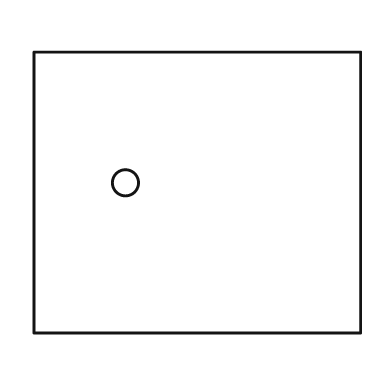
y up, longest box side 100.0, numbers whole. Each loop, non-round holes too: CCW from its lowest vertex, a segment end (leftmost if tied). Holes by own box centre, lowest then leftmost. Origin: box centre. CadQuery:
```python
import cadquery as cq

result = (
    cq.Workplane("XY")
    .moveTo(-50.0, -43.0)
    .lineTo(50.0, -43.0)
    .lineTo(50.0, 43.0)
    .lineTo(-50.0, 43.0)
    .close()
    .moveTo(-22.0, 3.0)
    .circle(4.0)
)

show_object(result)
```